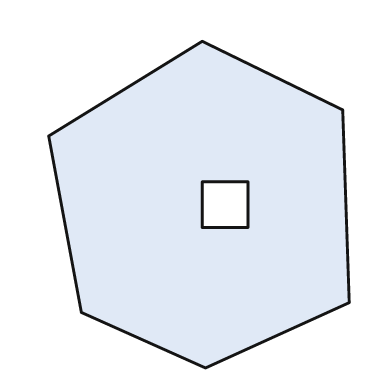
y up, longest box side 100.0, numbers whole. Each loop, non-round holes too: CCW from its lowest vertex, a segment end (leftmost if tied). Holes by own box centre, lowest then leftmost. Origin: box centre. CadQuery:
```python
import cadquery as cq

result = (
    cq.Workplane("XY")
    .moveTo(2.0, -50.0)
    .lineTo(46.0, -30.0)
    .lineTo(44.0, 29.0)
    .lineTo(1.0, 50.0)
    .lineTo(-46.0, 21.0)
    .lineTo(-36.0, -33.0)
    .close()
    .moveTo(1.0, -7.0)
    .lineTo(15.0, -7.0)
    .lineTo(15.0, 7.0)
    .lineTo(1.0, 7.0)
    .close()
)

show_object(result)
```